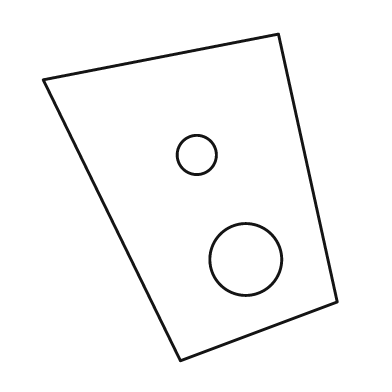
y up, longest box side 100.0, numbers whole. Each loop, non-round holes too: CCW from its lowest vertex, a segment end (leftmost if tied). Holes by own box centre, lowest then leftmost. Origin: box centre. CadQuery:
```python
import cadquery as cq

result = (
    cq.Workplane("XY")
    .moveTo(-3.0, -50.0)
    .lineTo(45.0, -32.0)
    .lineTo(27.0, 50.0)
    .lineTo(-45.0, 36.0)
    .close()
    .moveTo(17.0, -19.0)
    .circle(11.0)
    .moveTo(2.0, 13.0)
    .circle(6.0)
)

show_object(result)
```